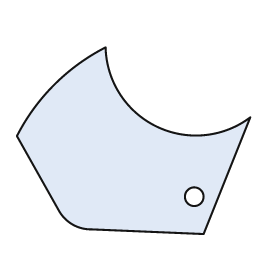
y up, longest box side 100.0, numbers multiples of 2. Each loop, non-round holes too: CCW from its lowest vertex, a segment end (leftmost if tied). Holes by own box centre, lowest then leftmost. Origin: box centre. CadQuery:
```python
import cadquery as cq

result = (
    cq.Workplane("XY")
    .moveTo(30.0, -40.0)
    .lineTo(50.0, 10.0)
    .threePointArc((10.0, 6.0), (-12.0, 40.0))
    .threePointArc((-34.0, 24.0), (-50.0, 2.0))
    .lineTo(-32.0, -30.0)
    .threePointArc((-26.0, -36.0), (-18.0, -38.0))
    .close()
    .moveTo(26.0, -24.0)
    .circle(4.0)
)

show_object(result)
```